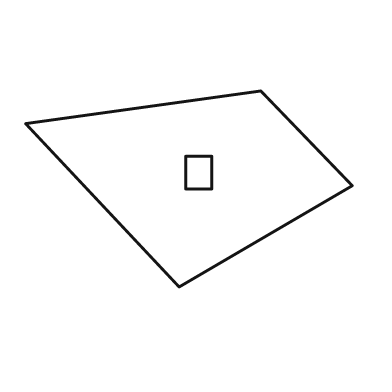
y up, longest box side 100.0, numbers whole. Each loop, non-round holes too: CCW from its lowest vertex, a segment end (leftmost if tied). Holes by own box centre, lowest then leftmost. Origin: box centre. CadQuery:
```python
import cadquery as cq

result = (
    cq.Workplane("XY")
    .moveTo(-3.0, -30.0)
    .lineTo(50.0, 1.0)
    .lineTo(22.0, 30.0)
    .lineTo(-50.0, 20.0)
    .close()
    .moveTo(-1.0, 0.0)
    .lineTo(7.0, 0.0)
    .lineTo(7.0, 10.0)
    .lineTo(-1.0, 10.0)
    .close()
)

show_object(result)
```